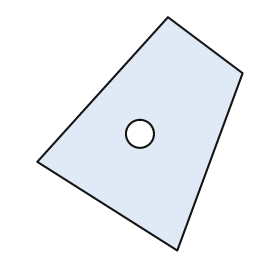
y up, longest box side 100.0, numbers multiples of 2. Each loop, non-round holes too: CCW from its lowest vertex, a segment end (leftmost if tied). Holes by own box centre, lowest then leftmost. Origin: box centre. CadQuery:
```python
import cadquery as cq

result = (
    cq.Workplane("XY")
    .moveTo(16.0, -50.0)
    .lineTo(44.0, 26.0)
    .lineTo(12.0, 50.0)
    .lineTo(-44.0, -12.0)
    .close()
    .moveTo(0.0, 0.0)
    .circle(6.0)
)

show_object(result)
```